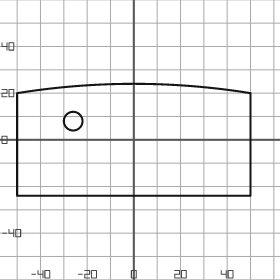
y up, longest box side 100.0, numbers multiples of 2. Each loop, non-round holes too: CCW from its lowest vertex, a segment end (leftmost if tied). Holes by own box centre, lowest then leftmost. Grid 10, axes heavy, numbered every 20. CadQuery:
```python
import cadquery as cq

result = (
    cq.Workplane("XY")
    .moveTo(-50.0, -24.0)
    .lineTo(50.0, -24.0)
    .lineTo(50.0, 20.0)
    .threePointArc((0.0, 24.0), (-50.0, 20.0))
    .close()
    .moveTo(-26.0, 8.0)
    .circle(4.0)
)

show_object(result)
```